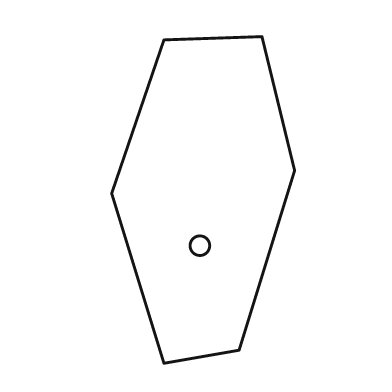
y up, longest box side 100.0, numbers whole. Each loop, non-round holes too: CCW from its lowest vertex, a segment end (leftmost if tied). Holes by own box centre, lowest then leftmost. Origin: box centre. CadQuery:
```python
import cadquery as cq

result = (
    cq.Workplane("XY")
    .moveTo(-12.0, -50.0)
    .lineTo(11.0, -46.0)
    .lineTo(28.0, 9.0)
    .lineTo(18.0, 50.0)
    .lineTo(-12.0, 49.0)
    .lineTo(-28.0, 2.0)
    .close()
    .moveTo(-1.0, -14.0)
    .circle(3.0)
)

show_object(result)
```